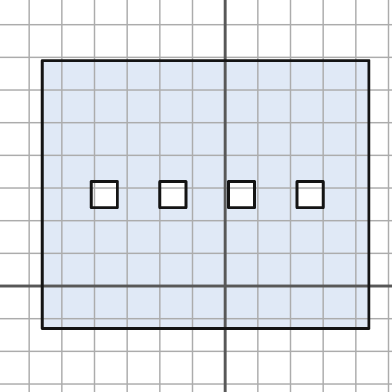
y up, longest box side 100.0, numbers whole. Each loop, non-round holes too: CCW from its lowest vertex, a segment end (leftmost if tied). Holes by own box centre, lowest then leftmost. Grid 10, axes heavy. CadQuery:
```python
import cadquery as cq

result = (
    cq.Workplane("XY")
    .moveTo(-56.0, -13.0)
    .lineTo(44.0, -13.0)
    .lineTo(44.0, 69.0)
    .lineTo(-56.0, 69.0)
    .close()
    .moveTo(-41.0, 24.0)
    .lineTo(-33.0, 24.0)
    .lineTo(-33.0, 32.0)
    .lineTo(-41.0, 32.0)
    .close()
    .moveTo(-20.0, 24.0)
    .lineTo(-12.0, 24.0)
    .lineTo(-12.0, 32.0)
    .lineTo(-20.0, 32.0)
    .close()
    .moveTo(1.0, 24.0)
    .lineTo(9.0, 24.0)
    .lineTo(9.0, 32.0)
    .lineTo(1.0, 32.0)
    .close()
    .moveTo(22.0, 24.0)
    .lineTo(30.0, 24.0)
    .lineTo(30.0, 32.0)
    .lineTo(22.0, 32.0)
    .close()
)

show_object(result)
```